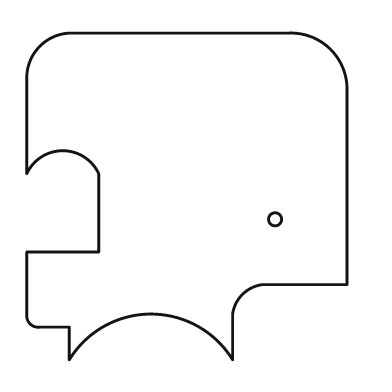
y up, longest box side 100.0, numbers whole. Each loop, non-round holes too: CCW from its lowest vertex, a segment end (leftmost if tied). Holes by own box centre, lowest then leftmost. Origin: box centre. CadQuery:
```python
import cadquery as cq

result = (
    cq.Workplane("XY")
    .moveTo(-36.0, -50.0)
    .threePointArc((-11.0, -36.0), (14.0, -50.0))
    .lineTo(14.0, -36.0)
    .threePointArc((17.0, -30.0), (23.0, -27.0))
    .lineTo(49.0, -27.0)
    .lineTo(49.0, 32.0)
    .threePointArc((44.0, 45.0), (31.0, 50.0))
    .lineTo(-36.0, 50.0)
    .threePointArc((-45.0, 46.0), (-49.0, 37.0))
    .lineTo(-49.0, 7.0)
    .threePointArc((-38.0, 14.0), (-27.0, 7.0))
    .lineTo(-27.0, -17.0)
    .lineTo(-49.0, -17.0)
    .lineTo(-49.0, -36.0)
    .threePointArc((-48.0, -39.0), (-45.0, -40.0))
    .lineTo(-36.0, -40.0)
    .close()
    .moveTo(27.0, -7.0)
    .circle(2.0)
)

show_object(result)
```